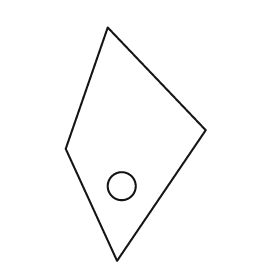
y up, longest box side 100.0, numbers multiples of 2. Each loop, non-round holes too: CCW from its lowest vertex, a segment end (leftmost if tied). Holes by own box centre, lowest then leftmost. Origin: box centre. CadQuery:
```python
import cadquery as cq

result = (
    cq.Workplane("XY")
    .moveTo(-8.0, -50.0)
    .lineTo(30.0, 6.0)
    .lineTo(-12.0, 50.0)
    .lineTo(-30.0, -2.0)
    .close()
    .moveTo(-6.0, -18.0)
    .circle(6.0)
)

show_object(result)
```